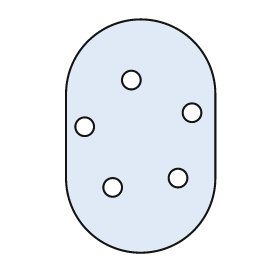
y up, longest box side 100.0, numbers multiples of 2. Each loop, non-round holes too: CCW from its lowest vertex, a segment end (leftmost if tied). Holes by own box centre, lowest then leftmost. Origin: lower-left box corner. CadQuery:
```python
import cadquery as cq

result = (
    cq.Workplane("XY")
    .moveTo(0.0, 32.0)
    .threePointArc((32.0, 0.0), (64.0, 32.0))
    .lineTo(64.0, 68.0)
    .threePointArc((32.0, 100.0), (0.0, 68.0))
    .close()
    .moveTo(20.0, 28.0)
    .circle(4.0)
    .moveTo(48.0, 32.0)
    .circle(4.0)
    .moveTo(8.0, 54.0)
    .circle(4.0)
    .moveTo(54.0, 60.0)
    .circle(4.0)
    .moveTo(28.0, 74.0)
    .circle(4.0)
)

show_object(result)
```